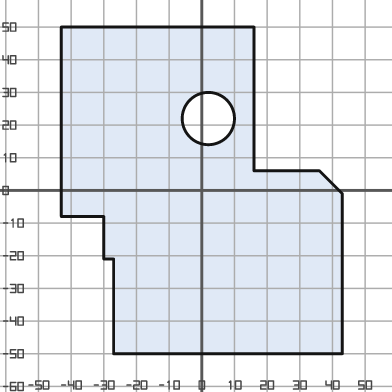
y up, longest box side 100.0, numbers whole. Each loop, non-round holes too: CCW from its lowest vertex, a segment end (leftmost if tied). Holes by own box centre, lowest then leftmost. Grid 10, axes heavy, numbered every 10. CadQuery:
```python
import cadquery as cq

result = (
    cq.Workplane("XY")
    .moveTo(-27.0, -50.0)
    .lineTo(43.0, -50.0)
    .lineTo(43.0, -1.0)
    .lineTo(36.0, 6.0)
    .lineTo(16.0, 6.0)
    .lineTo(16.0, 50.0)
    .lineTo(-43.0, 50.0)
    .lineTo(-43.0, -8.0)
    .lineTo(-30.0, -8.0)
    .lineTo(-30.0, -21.0)
    .lineTo(-27.0, -21.0)
    .close()
    .moveTo(2.0, 22.0)
    .circle(8.0)
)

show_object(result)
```